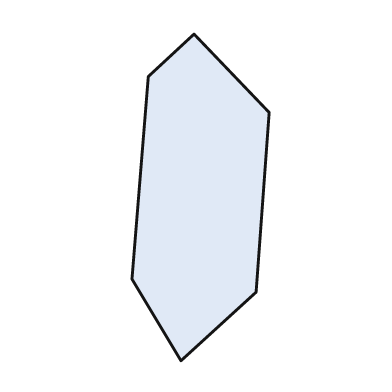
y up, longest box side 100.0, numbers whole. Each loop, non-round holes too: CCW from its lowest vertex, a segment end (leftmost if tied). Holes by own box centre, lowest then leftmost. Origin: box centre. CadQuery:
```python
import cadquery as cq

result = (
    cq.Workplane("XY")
    .moveTo(-6.0, -50.0)
    .lineTo(17.0, -29.0)
    .lineTo(21.0, 26.0)
    .lineTo(-2.0, 50.0)
    .lineTo(-16.0, 37.0)
    .lineTo(-21.0, -25.0)
    .close()
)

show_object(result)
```